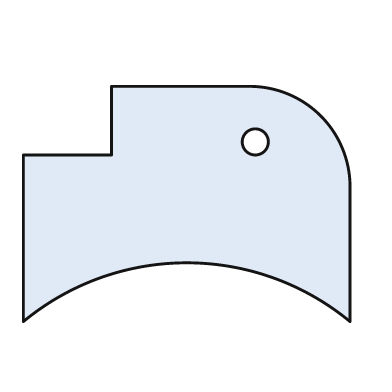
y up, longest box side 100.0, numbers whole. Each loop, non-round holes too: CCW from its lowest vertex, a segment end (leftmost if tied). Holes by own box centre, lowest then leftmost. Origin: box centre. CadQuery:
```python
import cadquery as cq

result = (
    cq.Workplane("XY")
    .moveTo(-50.0, -36.0)
    .threePointArc((0.0, -18.0), (50.0, -36.0))
    .lineTo(50.0, 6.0)
    .threePointArc((41.0, 27.0), (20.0, 36.0))
    .lineTo(-23.0, 36.0)
    .lineTo(-23.0, 15.0)
    .lineTo(-50.0, 15.0)
    .close()
    .moveTo(21.0, 19.0)
    .circle(4.0)
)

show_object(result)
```